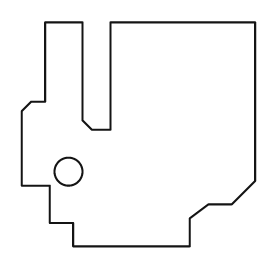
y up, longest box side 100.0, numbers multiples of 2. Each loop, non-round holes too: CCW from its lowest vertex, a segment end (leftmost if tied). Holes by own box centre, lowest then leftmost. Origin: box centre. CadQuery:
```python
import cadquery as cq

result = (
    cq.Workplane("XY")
    .moveTo(-28.0, -48.0)
    .lineTo(22.0, -48.0)
    .lineTo(22.0, -36.0)
    .lineTo(30.0, -30.0)
    .lineTo(40.0, -30.0)
    .lineTo(50.0, -20.0)
    .lineTo(50.0, 48.0)
    .lineTo(-12.0, 48.0)
    .lineTo(-12.0, 2.0)
    .lineTo(-20.0, 2.0)
    .lineTo(-24.0, 6.0)
    .lineTo(-24.0, 48.0)
    .lineTo(-40.0, 48.0)
    .lineTo(-40.0, 14.0)
    .lineTo(-46.0, 14.0)
    .lineTo(-50.0, 10.0)
    .lineTo(-50.0, -22.0)
    .lineTo(-38.0, -22.0)
    .lineTo(-38.0, -38.0)
    .lineTo(-28.0, -38.0)
    .close()
    .moveTo(-30.0, -16.0)
    .circle(6.0)
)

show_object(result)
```